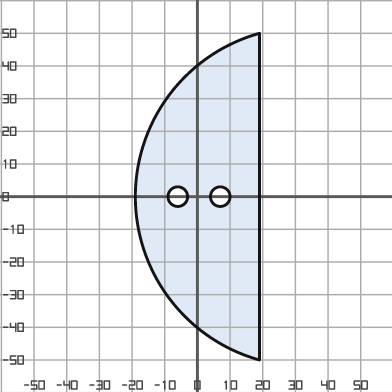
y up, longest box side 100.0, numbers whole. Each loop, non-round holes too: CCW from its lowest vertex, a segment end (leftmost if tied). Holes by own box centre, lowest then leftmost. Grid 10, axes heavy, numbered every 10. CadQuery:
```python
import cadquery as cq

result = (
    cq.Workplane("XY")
    .moveTo(19.0, -50.0)
    .lineTo(19.0, 50.0)
    .threePointArc((-19.0, 0.0), (19.0, -50.0))
    .close()
    .moveTo(-6.0, 0.0)
    .circle(3.0)
    .moveTo(7.0, 0.0)
    .circle(3.0)
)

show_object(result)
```